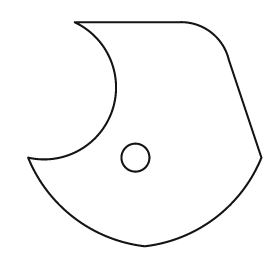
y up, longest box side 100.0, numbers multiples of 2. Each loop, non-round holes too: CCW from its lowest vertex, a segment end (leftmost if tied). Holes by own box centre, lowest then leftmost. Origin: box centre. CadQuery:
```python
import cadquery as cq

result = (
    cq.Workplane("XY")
    .moveTo(0.0, -48.0)
    .threePointArc((30.0, -36.0), (50.0, -10.0))
    .lineTo(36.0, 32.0)
    .threePointArc((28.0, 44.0), (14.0, 48.0))
    .lineTo(-30.0, 48.0)
    .threePointArc((-14.0, 10.0), (-50.0, -10.0))
    .threePointArc((-30.0, -36.0), (0.0, -48.0))
    .close()
    .moveTo(-4.0, -10.0)
    .circle(6.0)
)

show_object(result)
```